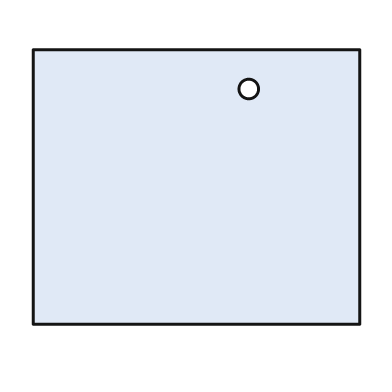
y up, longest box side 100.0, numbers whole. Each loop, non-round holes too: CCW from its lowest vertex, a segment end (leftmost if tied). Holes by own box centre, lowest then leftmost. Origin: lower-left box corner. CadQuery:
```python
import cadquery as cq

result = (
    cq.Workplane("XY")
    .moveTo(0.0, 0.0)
    .lineTo(100.0, 0.0)
    .lineTo(100.0, 84.0)
    .lineTo(0.0, 84.0)
    .close()
    .moveTo(66.0, 72.0)
    .circle(3.0)
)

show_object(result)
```